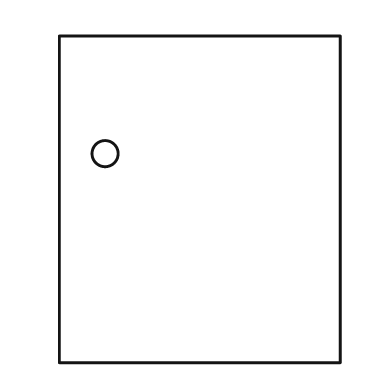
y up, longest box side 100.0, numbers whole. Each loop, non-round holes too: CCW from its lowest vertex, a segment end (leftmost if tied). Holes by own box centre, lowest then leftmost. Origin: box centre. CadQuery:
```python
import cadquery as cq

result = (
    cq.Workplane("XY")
    .moveTo(-43.0, -50.0)
    .lineTo(43.0, -50.0)
    .lineTo(43.0, 50.0)
    .lineTo(-43.0, 50.0)
    .close()
    .moveTo(-29.0, 14.0)
    .circle(4.0)
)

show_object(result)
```